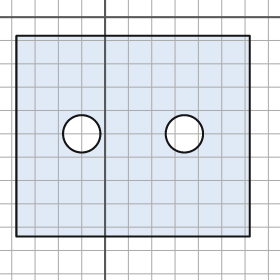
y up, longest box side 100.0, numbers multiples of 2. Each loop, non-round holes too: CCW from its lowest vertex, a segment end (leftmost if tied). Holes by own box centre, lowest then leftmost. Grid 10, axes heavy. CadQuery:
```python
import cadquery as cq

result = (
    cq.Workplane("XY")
    .moveTo(-38.0, -94.0)
    .lineTo(62.0, -94.0)
    .lineTo(62.0, -8.0)
    .lineTo(-38.0, -8.0)
    .close()
    .moveTo(-10.0, -50.0)
    .circle(8.0)
    .moveTo(34.0, -50.0)
    .circle(8.0)
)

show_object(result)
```